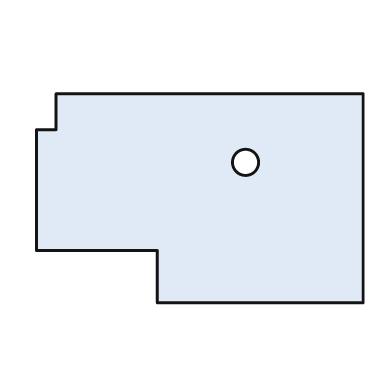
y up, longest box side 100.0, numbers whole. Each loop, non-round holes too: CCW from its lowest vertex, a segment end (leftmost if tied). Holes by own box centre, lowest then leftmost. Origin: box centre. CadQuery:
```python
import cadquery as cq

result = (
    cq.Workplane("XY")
    .moveTo(-13.0, -32.0)
    .lineTo(50.0, -32.0)
    .lineTo(50.0, 32.0)
    .lineTo(-44.0, 32.0)
    .lineTo(-44.0, 21.0)
    .lineTo(-50.0, 21.0)
    .lineTo(-50.0, -16.0)
    .lineTo(-13.0, -16.0)
    .close()
    .moveTo(14.0, 11.0)
    .circle(4.0)
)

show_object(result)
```